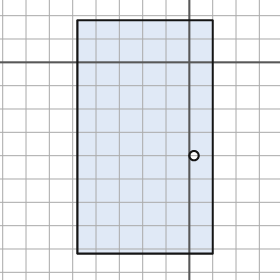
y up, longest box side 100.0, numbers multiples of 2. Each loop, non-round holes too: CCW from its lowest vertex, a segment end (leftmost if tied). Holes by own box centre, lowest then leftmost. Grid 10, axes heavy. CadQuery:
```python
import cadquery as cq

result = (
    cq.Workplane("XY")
    .moveTo(-48.0, -82.0)
    .lineTo(10.0, -82.0)
    .lineTo(10.0, 18.0)
    .lineTo(-48.0, 18.0)
    .close()
    .moveTo(2.0, -40.0)
    .circle(2.0)
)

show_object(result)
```